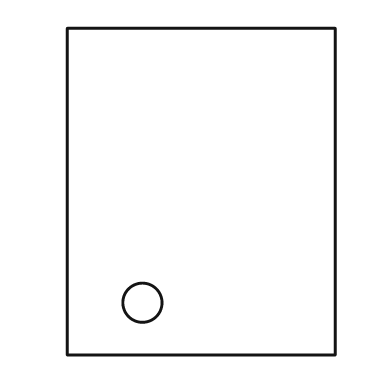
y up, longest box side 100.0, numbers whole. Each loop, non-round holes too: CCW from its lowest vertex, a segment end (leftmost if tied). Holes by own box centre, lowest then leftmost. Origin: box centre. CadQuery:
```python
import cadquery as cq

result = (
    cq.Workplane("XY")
    .moveTo(-41.0, -50.0)
    .lineTo(41.0, -50.0)
    .lineTo(41.0, 50.0)
    .lineTo(-41.0, 50.0)
    .close()
    .moveTo(-18.0, -34.0)
    .circle(6.0)
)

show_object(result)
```